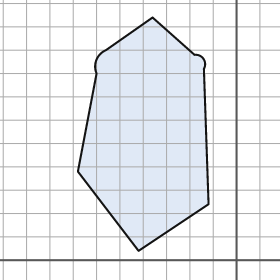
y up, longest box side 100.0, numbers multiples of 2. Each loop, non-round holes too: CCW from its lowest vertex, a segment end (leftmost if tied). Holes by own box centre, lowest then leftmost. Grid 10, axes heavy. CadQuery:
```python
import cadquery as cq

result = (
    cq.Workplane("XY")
    .moveTo(-42.0, 4.0)
    .lineTo(-12.0, 24.0)
    .lineTo(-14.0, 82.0)
    .threePointArc((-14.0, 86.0), (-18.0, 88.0))
    .lineTo(-36.0, 104.0)
    .lineTo(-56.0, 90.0)
    .threePointArc((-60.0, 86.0), (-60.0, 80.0))
    .lineTo(-68.0, 38.0)
    .close()
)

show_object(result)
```